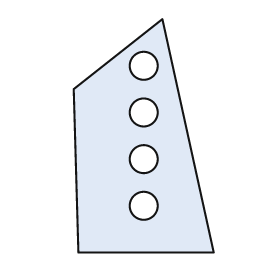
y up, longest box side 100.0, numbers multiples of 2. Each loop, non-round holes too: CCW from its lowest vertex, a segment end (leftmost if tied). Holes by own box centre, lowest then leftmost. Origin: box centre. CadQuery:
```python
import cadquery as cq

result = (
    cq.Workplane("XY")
    .moveTo(-28.0, -50.0)
    .lineTo(30.0, -50.0)
    .lineTo(8.0, 50.0)
    .lineTo(-30.0, 20.0)
    .close()
    .moveTo(0.0, -30.0)
    .circle(6.0)
    .moveTo(0.0, -10.0)
    .circle(6.0)
    .moveTo(0.0, 10.0)
    .circle(6.0)
    .moveTo(0.0, 30.0)
    .circle(6.0)
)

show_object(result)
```